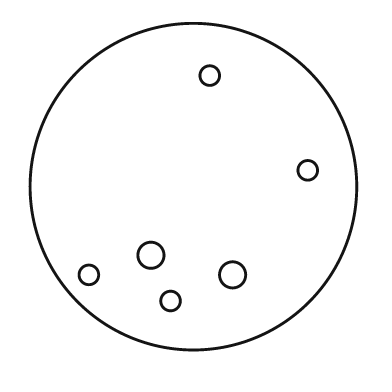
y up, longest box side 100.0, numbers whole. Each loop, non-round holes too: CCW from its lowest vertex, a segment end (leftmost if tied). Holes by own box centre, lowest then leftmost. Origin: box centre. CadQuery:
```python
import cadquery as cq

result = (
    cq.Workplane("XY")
    .moveTo(0.0, 0.0)
    .circle(50.0)
    .moveTo(-7.0, -35.0)
    .circle(3.0)
    .moveTo(-32.0, -27.0)
    .circle(3.0)
    .moveTo(12.0, -27.0)
    .circle(4.0)
    .moveTo(-13.0, -21.0)
    .circle(4.0)
    .moveTo(35.0, 5.0)
    .circle(3.0)
    .moveTo(5.0, 34.0)
    .circle(3.0)
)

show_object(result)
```